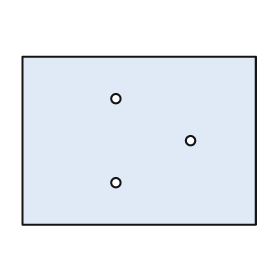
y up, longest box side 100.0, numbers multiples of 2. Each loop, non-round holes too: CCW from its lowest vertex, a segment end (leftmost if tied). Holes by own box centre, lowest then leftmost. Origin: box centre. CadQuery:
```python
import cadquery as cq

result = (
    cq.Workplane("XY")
    .moveTo(-50.0, -36.0)
    .lineTo(50.0, -36.0)
    .lineTo(50.0, 36.0)
    .lineTo(-50.0, 36.0)
    .close()
    .moveTo(-10.0, -18.0)
    .circle(2.0)
    .moveTo(22.0, 0.0)
    .circle(2.0)
    .moveTo(-10.0, 18.0)
    .circle(2.0)
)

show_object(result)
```